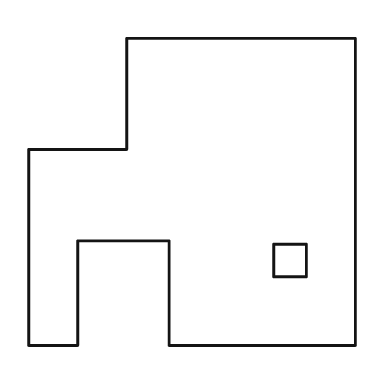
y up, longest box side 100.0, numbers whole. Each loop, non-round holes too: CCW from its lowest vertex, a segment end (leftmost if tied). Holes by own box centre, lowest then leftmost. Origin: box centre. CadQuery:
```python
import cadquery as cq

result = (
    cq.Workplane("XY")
    .moveTo(-50.0, -47.0)
    .lineTo(-35.0, -47.0)
    .lineTo(-35.0, -15.0)
    .lineTo(-7.0, -15.0)
    .lineTo(-7.0, -47.0)
    .lineTo(50.0, -47.0)
    .lineTo(50.0, 47.0)
    .lineTo(-20.0, 47.0)
    .lineTo(-20.0, 13.0)
    .lineTo(-50.0, 13.0)
    .close()
    .moveTo(25.0, -26.0)
    .lineTo(35.0, -26.0)
    .lineTo(35.0, -16.0)
    .lineTo(25.0, -16.0)
    .close()
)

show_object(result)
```